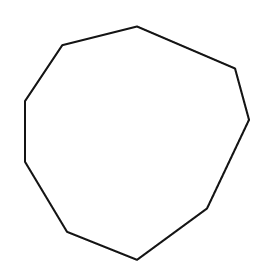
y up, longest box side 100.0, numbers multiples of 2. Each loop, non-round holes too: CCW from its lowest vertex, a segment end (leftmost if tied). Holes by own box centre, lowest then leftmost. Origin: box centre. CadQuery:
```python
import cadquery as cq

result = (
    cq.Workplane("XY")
    .moveTo(0.0, -50.0)
    .lineTo(30.0, -28.0)
    .lineTo(48.0, 10.0)
    .lineTo(42.0, 32.0)
    .lineTo(0.0, 50.0)
    .lineTo(-32.0, 42.0)
    .lineTo(-48.0, 18.0)
    .lineTo(-48.0, -8.0)
    .lineTo(-30.0, -38.0)
    .close()
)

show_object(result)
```